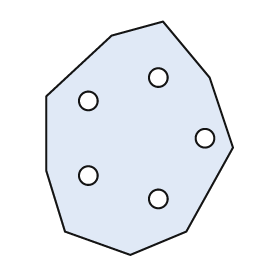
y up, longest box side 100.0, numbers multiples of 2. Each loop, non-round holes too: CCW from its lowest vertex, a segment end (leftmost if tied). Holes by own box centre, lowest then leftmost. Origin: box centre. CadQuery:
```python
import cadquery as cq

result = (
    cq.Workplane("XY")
    .moveTo(-4.0, -50.0)
    .lineTo(20.0, -40.0)
    .lineTo(40.0, -4.0)
    .lineTo(30.0, 26.0)
    .lineTo(10.0, 50.0)
    .lineTo(-12.0, 44.0)
    .lineTo(-40.0, 18.0)
    .lineTo(-40.0, -14.0)
    .lineTo(-32.0, -40.0)
    .close()
    .moveTo(8.0, -26.0)
    .circle(4.0)
    .moveTo(-22.0, -16.0)
    .circle(4.0)
    .moveTo(28.0, 0.0)
    .circle(4.0)
    .moveTo(-22.0, 16.0)
    .circle(4.0)
    .moveTo(8.0, 26.0)
    .circle(4.0)
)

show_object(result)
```